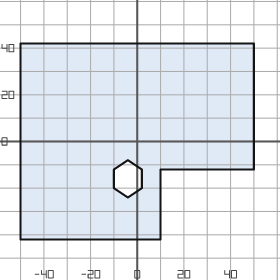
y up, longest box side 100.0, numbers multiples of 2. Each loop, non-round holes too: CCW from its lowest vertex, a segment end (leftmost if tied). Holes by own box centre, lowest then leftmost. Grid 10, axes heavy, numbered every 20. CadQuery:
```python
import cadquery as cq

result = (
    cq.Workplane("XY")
    .moveTo(-50.0, -42.0)
    .lineTo(10.0, -42.0)
    .lineTo(10.0, -12.0)
    .lineTo(50.0, -12.0)
    .lineTo(50.0, 42.0)
    .lineTo(-50.0, 42.0)
    .close()
    .moveTo(-4.0, -24.0)
    .lineTo(2.0, -20.0)
    .lineTo(2.0, -12.0)
    .lineTo(-4.0, -8.0)
    .lineTo(-10.0, -12.0)
    .lineTo(-10.0, -20.0)
    .close()
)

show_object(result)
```